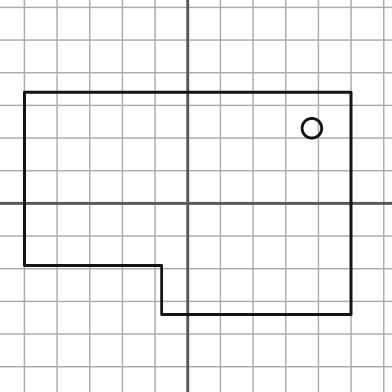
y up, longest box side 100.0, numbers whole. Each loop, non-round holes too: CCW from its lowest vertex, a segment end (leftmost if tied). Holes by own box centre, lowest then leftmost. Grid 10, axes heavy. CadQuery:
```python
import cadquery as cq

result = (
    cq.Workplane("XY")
    .moveTo(-8.0, -34.0)
    .lineTo(50.0, -34.0)
    .lineTo(50.0, 34.0)
    .lineTo(-50.0, 34.0)
    .lineTo(-50.0, -19.0)
    .lineTo(-8.0, -19.0)
    .close()
    .moveTo(38.0, 23.0)
    .circle(3.0)
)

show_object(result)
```